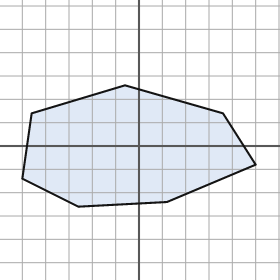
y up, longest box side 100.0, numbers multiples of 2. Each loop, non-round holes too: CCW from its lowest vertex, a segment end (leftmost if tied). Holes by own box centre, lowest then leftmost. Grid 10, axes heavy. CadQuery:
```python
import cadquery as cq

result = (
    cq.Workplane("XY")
    .moveTo(-26.0, -26.0)
    .lineTo(12.0, -24.0)
    .lineTo(50.0, -8.0)
    .lineTo(36.0, 14.0)
    .lineTo(-6.0, 26.0)
    .lineTo(-46.0, 14.0)
    .lineTo(-50.0, -14.0)
    .close()
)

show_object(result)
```